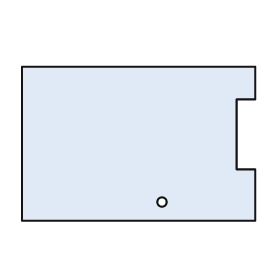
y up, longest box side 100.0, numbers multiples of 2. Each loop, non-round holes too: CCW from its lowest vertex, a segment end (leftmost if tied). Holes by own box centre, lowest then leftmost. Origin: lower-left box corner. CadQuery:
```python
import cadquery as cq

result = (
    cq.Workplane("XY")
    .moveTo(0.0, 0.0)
    .lineTo(100.0, 0.0)
    .lineTo(100.0, 22.0)
    .lineTo(92.0, 22.0)
    .lineTo(92.0, 52.0)
    .lineTo(100.0, 52.0)
    .lineTo(100.0, 66.0)
    .lineTo(0.0, 66.0)
    .close()
    .moveTo(60.0, 8.0)
    .circle(2.0)
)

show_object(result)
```